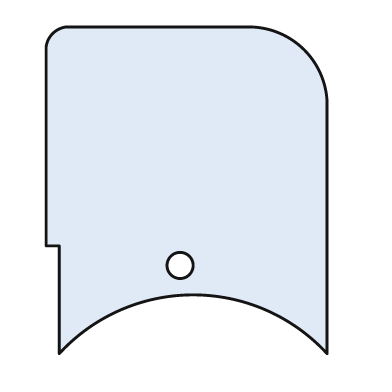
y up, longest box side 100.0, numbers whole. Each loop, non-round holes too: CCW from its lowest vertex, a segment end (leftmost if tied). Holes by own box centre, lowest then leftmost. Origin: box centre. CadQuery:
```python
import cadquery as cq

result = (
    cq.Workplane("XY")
    .moveTo(-39.0, -50.0)
    .threePointArc((2.0, -32.0), (43.0, -50.0))
    .lineTo(43.0, 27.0)
    .threePointArc((36.0, 43.0), (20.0, 50.0))
    .lineTo(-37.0, 50.0)
    .threePointArc((-41.0, 48.0), (-43.0, 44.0))
    .lineTo(-43.0, -17.0)
    .lineTo(-39.0, -17.0)
    .close()
    .moveTo(-2.0, -23.0)
    .circle(4.0)
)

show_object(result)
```